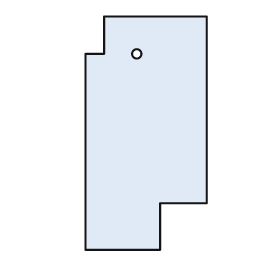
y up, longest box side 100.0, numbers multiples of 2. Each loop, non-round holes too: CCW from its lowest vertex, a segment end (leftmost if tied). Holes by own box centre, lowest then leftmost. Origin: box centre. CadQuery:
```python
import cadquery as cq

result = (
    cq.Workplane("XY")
    .moveTo(-26.0, -50.0)
    .lineTo(6.0, -50.0)
    .lineTo(6.0, -30.0)
    .lineTo(26.0, -30.0)
    .lineTo(26.0, 50.0)
    .lineTo(-18.0, 50.0)
    .lineTo(-18.0, 34.0)
    .lineTo(-26.0, 34.0)
    .close()
    .moveTo(-4.0, 34.0)
    .circle(2.0)
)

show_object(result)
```